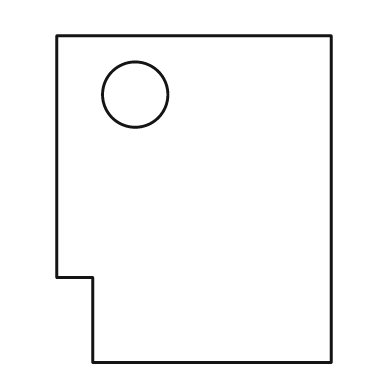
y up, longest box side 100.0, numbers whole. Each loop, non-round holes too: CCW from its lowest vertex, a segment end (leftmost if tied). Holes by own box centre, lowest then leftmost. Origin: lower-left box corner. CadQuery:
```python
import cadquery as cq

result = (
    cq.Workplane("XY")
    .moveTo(11.0, 0.0)
    .lineTo(84.0, 0.0)
    .lineTo(84.0, 100.0)
    .lineTo(0.0, 100.0)
    .lineTo(0.0, 26.0)
    .lineTo(11.0, 26.0)
    .close()
    .moveTo(24.0, 82.0)
    .circle(10.0)
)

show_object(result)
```